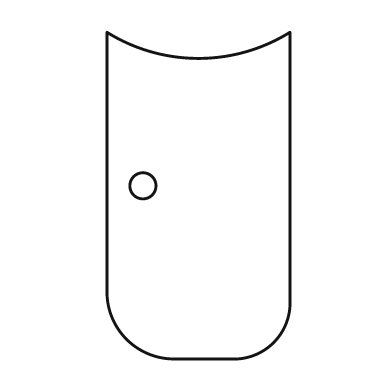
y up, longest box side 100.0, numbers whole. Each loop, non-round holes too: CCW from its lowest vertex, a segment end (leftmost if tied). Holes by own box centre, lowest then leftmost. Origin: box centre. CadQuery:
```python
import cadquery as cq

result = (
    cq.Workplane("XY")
    .moveTo(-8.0, -50.0)
    .lineTo(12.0, -50.0)
    .threePointArc((23.0, -45.0), (28.0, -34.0))
    .lineTo(28.0, 50.0)
    .threePointArc((0.0, 42.0), (-28.0, 50.0))
    .lineTo(-28.0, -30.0)
    .threePointArc((-22.0, -44.0), (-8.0, -50.0))
    .close()
    .moveTo(-17.0, 3.0)
    .circle(4.0)
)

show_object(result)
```